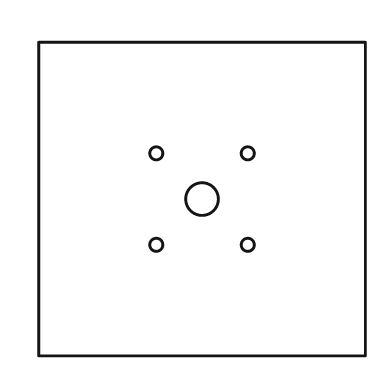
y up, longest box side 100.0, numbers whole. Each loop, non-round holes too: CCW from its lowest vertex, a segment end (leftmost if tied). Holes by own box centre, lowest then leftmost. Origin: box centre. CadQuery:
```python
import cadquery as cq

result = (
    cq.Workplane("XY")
    .moveTo(-50.0, -48.0)
    .lineTo(50.0, -48.0)
    .lineTo(50.0, 48.0)
    .lineTo(-50.0, 48.0)
    .close()
    .moveTo(-14.0, -14.0)
    .circle(2.0)
    .moveTo(14.0, -14.0)
    .circle(2.0)
    .moveTo(0.0, 0.0)
    .circle(5.0)
    .moveTo(-14.0, 14.0)
    .circle(2.0)
    .moveTo(14.0, 14.0)
    .circle(2.0)
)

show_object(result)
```